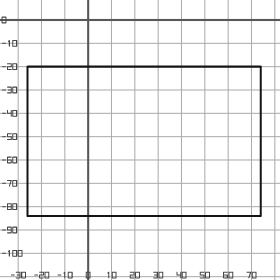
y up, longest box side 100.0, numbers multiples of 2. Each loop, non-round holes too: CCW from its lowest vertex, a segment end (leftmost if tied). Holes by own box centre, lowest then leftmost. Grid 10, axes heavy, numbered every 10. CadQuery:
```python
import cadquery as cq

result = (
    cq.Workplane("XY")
    .moveTo(-26.0, -84.0)
    .lineTo(74.0, -84.0)
    .lineTo(74.0, -20.0)
    .lineTo(-26.0, -20.0)
    .close()
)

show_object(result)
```